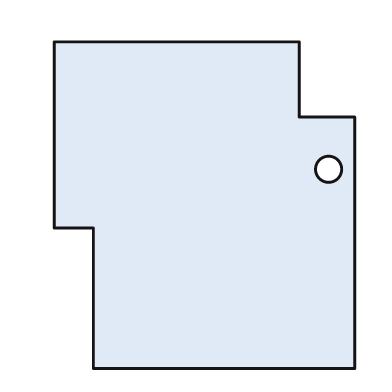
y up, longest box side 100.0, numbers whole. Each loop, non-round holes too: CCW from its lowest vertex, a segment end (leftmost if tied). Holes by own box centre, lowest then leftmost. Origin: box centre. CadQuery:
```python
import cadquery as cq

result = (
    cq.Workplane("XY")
    .moveTo(-34.0, -50.0)
    .lineTo(46.0, -50.0)
    .lineTo(46.0, 27.0)
    .lineTo(29.0, 27.0)
    .lineTo(29.0, 50.0)
    .lineTo(-46.0, 50.0)
    .lineTo(-46.0, -7.0)
    .lineTo(-34.0, -7.0)
    .close()
    .moveTo(38.0, 11.0)
    .circle(4.0)
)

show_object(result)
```